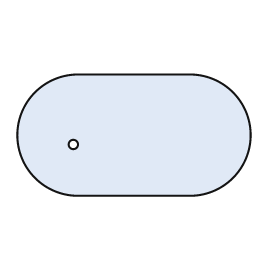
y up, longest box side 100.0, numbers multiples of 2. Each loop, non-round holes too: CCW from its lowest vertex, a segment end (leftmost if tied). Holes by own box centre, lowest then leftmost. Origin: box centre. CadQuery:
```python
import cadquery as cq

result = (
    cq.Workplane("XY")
    .moveTo(-24.0, -26.0)
    .lineTo(24.0, -26.0)
    .threePointArc((50.0, 0.0), (24.0, 26.0))
    .lineTo(-24.0, 26.0)
    .threePointArc((-50.0, 0.0), (-24.0, -26.0))
    .close()
    .moveTo(-26.0, -4.0)
    .circle(2.0)
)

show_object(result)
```